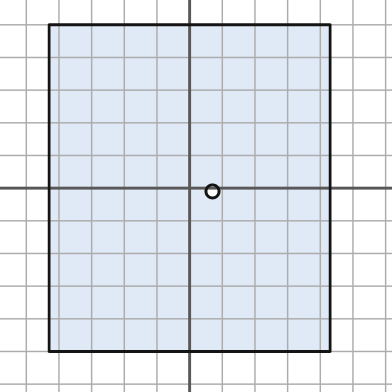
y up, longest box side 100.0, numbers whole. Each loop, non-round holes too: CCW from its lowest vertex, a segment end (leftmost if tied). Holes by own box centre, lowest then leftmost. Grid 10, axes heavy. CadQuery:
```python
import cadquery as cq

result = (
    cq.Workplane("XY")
    .moveTo(-43.0, -50.0)
    .lineTo(43.0, -50.0)
    .lineTo(43.0, 50.0)
    .lineTo(-43.0, 50.0)
    .close()
    .moveTo(7.0, -1.0)
    .circle(2.0)
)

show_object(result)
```